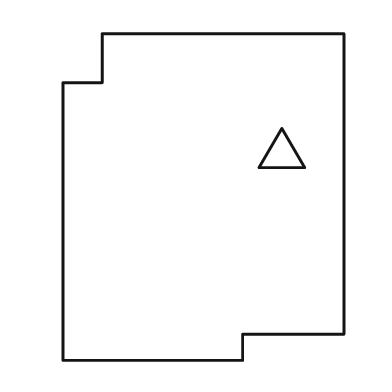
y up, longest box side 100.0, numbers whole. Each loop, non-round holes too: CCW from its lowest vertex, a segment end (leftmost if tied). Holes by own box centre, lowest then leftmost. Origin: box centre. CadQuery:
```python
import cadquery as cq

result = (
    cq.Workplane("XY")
    .moveTo(-43.0, -50.0)
    .lineTo(12.0, -50.0)
    .lineTo(12.0, -42.0)
    .lineTo(43.0, -42.0)
    .lineTo(43.0, 50.0)
    .lineTo(-31.0, 50.0)
    .lineTo(-31.0, 35.0)
    .lineTo(-43.0, 35.0)
    .close()
    .moveTo(17.0, 9.0)
    .lineTo(31.0, 9.0)
    .lineTo(24.0, 21.0)
    .close()
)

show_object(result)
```